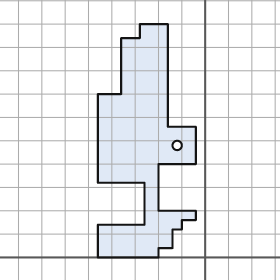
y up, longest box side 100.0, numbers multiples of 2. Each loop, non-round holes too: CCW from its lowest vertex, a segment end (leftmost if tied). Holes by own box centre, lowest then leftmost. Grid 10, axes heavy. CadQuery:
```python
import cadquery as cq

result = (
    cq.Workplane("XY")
    .moveTo(-46.0, 0.0)
    .lineTo(-20.0, 0.0)
    .lineTo(-20.0, 4.0)
    .lineTo(-14.0, 4.0)
    .lineTo(-14.0, 12.0)
    .lineTo(-10.0, 12.0)
    .lineTo(-10.0, 16.0)
    .lineTo(-4.0, 16.0)
    .lineTo(-4.0, 20.0)
    .lineTo(-20.0, 20.0)
    .lineTo(-20.0, 40.0)
    .lineTo(-4.0, 40.0)
    .lineTo(-4.0, 56.0)
    .lineTo(-16.0, 56.0)
    .lineTo(-16.0, 100.0)
    .lineTo(-28.0, 100.0)
    .lineTo(-28.0, 94.0)
    .lineTo(-36.0, 94.0)
    .lineTo(-36.0, 70.0)
    .lineTo(-46.0, 70.0)
    .lineTo(-46.0, 32.0)
    .lineTo(-26.0, 32.0)
    .lineTo(-26.0, 14.0)
    .lineTo(-46.0, 14.0)
    .close()
    .moveTo(-12.0, 48.0)
    .circle(2.0)
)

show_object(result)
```